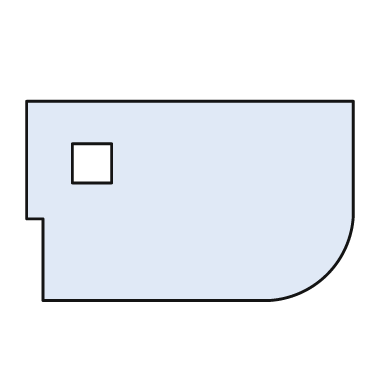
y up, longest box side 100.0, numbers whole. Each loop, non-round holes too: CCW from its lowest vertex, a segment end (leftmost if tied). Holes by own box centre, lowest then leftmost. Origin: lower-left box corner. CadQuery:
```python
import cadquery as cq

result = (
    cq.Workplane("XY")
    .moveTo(5.0, 0.0)
    .lineTo(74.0, 0.0)
    .threePointArc((92.0, 8.0), (100.0, 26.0))
    .lineTo(100.0, 61.0)
    .lineTo(0.0, 61.0)
    .lineTo(0.0, 25.0)
    .lineTo(5.0, 25.0)
    .close()
    .moveTo(14.0, 36.0)
    .lineTo(26.0, 36.0)
    .lineTo(26.0, 48.0)
    .lineTo(14.0, 48.0)
    .close()
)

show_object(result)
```